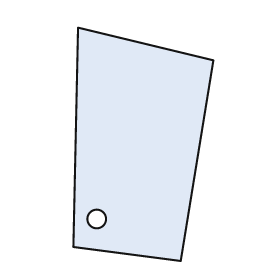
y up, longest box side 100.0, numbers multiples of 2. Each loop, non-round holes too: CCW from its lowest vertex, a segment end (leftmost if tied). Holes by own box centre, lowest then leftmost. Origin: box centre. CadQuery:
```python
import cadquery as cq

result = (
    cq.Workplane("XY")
    .moveTo(16.0, -50.0)
    .lineTo(30.0, 36.0)
    .lineTo(-28.0, 50.0)
    .lineTo(-30.0, -44.0)
    .close()
    .moveTo(-20.0, -32.0)
    .circle(4.0)
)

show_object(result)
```